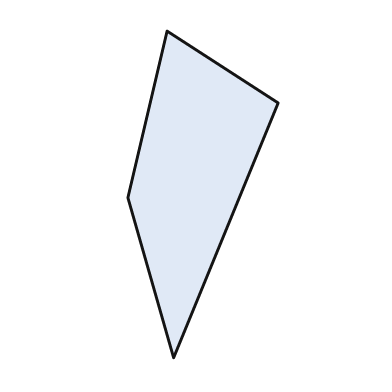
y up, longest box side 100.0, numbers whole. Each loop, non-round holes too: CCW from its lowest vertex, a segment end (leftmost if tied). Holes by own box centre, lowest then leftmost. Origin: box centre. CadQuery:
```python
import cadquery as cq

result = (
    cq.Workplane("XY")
    .moveTo(-9.0, -50.0)
    .lineTo(23.0, 28.0)
    .lineTo(-11.0, 50.0)
    .lineTo(-23.0, -1.0)
    .close()
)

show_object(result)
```